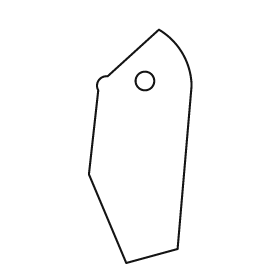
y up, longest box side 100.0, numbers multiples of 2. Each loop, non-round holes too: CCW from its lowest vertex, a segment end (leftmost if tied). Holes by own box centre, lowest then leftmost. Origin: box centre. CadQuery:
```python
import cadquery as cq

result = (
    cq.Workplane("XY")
    .moveTo(-6.0, -50.0)
    .lineTo(16.0, -44.0)
    .lineTo(22.0, 26.0)
    .threePointArc((18.0, 40.0), (8.0, 50.0))
    .lineTo(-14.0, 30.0)
    .threePointArc((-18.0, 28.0), (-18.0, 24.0))
    .lineTo(-22.0, -12.0)
    .close()
    .moveTo(2.0, 28.0)
    .circle(4.0)
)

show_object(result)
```